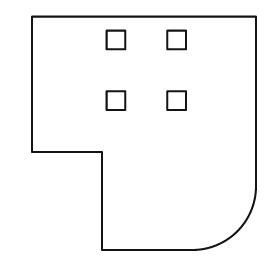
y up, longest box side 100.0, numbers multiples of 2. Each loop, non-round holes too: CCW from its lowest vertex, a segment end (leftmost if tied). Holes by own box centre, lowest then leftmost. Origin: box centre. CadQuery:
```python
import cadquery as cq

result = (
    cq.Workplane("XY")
    .moveTo(-18.0, -50.0)
    .lineTo(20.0, -50.0)
    .threePointArc((40.0, -42.0), (48.0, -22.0))
    .lineTo(48.0, 50.0)
    .lineTo(-48.0, 50.0)
    .lineTo(-48.0, -8.0)
    .lineTo(-18.0, -8.0)
    .close()
    .moveTo(-16.0, 10.0)
    .lineTo(-8.0, 10.0)
    .lineTo(-8.0, 18.0)
    .lineTo(-16.0, 18.0)
    .close()
    .moveTo(10.0, 10.0)
    .lineTo(18.0, 10.0)
    .lineTo(18.0, 18.0)
    .lineTo(10.0, 18.0)
    .close()
    .moveTo(-16.0, 36.0)
    .lineTo(-8.0, 36.0)
    .lineTo(-8.0, 44.0)
    .lineTo(-16.0, 44.0)
    .close()
    .moveTo(10.0, 36.0)
    .lineTo(18.0, 36.0)
    .lineTo(18.0, 44.0)
    .lineTo(10.0, 44.0)
    .close()
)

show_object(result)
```